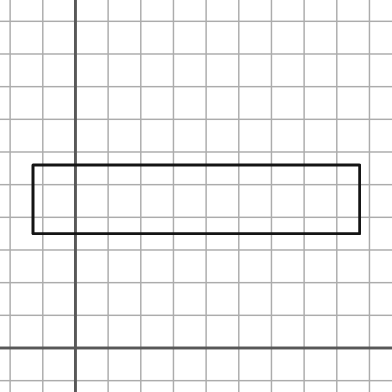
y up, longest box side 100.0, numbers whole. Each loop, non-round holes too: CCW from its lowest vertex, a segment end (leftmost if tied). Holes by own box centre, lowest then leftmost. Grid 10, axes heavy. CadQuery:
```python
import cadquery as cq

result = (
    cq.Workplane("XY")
    .moveTo(-13.0, 35.0)
    .lineTo(87.0, 35.0)
    .lineTo(87.0, 56.0)
    .lineTo(-13.0, 56.0)
    .close()
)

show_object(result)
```